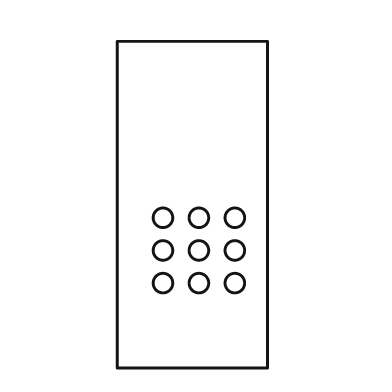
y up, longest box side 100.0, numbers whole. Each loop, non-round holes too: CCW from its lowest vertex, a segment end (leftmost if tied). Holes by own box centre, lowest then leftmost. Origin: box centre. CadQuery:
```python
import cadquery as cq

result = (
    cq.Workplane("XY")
    .moveTo(-23.0, -50.0)
    .lineTo(23.0, -50.0)
    .lineTo(23.0, 50.0)
    .lineTo(-23.0, 50.0)
    .close()
    .moveTo(-9.0, -24.0)
    .circle(3.0)
    .moveTo(2.0, -24.0)
    .circle(3.0)
    .moveTo(13.0, -24.0)
    .circle(3.0)
    .moveTo(-9.0, -14.0)
    .circle(3.0)
    .moveTo(2.0, -14.0)
    .circle(3.0)
    .moveTo(13.0, -14.0)
    .circle(3.0)
    .moveTo(-9.0, -4.0)
    .circle(3.0)
    .moveTo(2.0, -4.0)
    .circle(3.0)
    .moveTo(13.0, -4.0)
    .circle(3.0)
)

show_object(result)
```